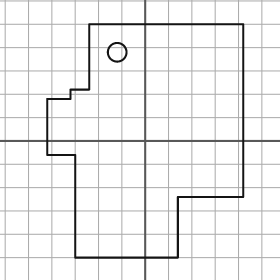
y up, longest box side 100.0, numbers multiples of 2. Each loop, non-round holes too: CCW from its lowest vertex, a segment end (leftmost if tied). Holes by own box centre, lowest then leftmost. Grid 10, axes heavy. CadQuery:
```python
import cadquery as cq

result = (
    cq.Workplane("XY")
    .moveTo(-30.0, -50.0)
    .lineTo(14.0, -50.0)
    .lineTo(14.0, -24.0)
    .lineTo(42.0, -24.0)
    .lineTo(42.0, 50.0)
    .lineTo(-24.0, 50.0)
    .lineTo(-24.0, 22.0)
    .lineTo(-32.0, 22.0)
    .lineTo(-32.0, 18.0)
    .lineTo(-42.0, 18.0)
    .lineTo(-42.0, -6.0)
    .lineTo(-30.0, -6.0)
    .close()
    .moveTo(-12.0, 38.0)
    .circle(4.0)
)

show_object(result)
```